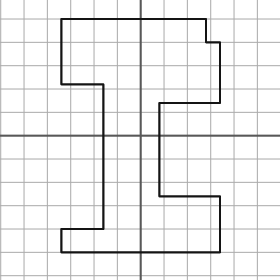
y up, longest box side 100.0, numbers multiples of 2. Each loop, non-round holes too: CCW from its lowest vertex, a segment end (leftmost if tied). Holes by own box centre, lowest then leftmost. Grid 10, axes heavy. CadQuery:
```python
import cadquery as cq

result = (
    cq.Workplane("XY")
    .moveTo(-34.0, -50.0)
    .lineTo(34.0, -50.0)
    .lineTo(34.0, -26.0)
    .lineTo(8.0, -26.0)
    .lineTo(8.0, 14.0)
    .lineTo(34.0, 14.0)
    .lineTo(34.0, 40.0)
    .lineTo(28.0, 40.0)
    .lineTo(28.0, 50.0)
    .lineTo(-34.0, 50.0)
    .lineTo(-34.0, 22.0)
    .lineTo(-16.0, 22.0)
    .lineTo(-16.0, -40.0)
    .lineTo(-34.0, -40.0)
    .close()
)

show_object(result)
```